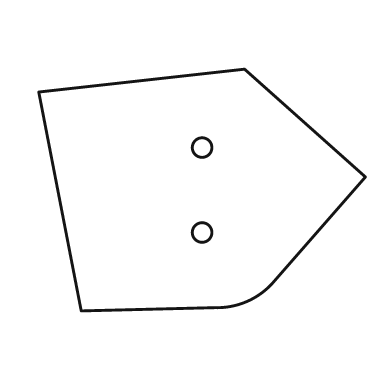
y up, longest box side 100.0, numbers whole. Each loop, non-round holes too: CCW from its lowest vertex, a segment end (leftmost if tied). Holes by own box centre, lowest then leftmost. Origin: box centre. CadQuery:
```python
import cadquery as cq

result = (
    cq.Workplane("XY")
    .moveTo(-37.0, -37.0)
    .lineTo(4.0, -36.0)
    .threePointArc((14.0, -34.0), (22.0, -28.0))
    .lineTo(50.0, 4.0)
    .lineTo(13.0, 37.0)
    .lineTo(-50.0, 30.0)
    .close()
    .moveTo(0.0, -13.0)
    .circle(3.0)
    .moveTo(0.0, 13.0)
    .circle(3.0)
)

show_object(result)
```